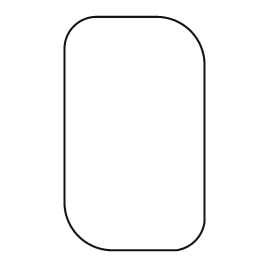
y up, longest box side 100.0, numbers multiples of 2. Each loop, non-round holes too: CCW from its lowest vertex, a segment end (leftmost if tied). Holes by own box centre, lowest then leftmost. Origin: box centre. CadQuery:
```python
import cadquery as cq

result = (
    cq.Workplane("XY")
    .moveTo(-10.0, -50.0)
    .lineTo(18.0, -50.0)
    .threePointArc((26.0, -46.0), (30.0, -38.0))
    .lineTo(30.0, 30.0)
    .threePointArc((24.0, 44.0), (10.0, 50.0))
    .lineTo(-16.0, 50.0)
    .threePointArc((-26.0, 46.0), (-30.0, 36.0))
    .lineTo(-30.0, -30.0)
    .threePointArc((-24.0, -44.0), (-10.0, -50.0))
    .close()
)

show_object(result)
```